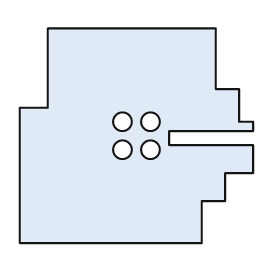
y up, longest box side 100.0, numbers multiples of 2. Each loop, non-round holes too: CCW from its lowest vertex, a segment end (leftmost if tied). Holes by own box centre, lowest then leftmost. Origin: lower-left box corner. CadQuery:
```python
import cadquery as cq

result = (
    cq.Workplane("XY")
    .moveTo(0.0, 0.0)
    .lineTo(78.0, 0.0)
    .lineTo(78.0, 18.0)
    .lineTo(88.0, 18.0)
    .lineTo(88.0, 30.0)
    .lineTo(100.0, 30.0)
    .lineTo(100.0, 42.0)
    .lineTo(64.0, 42.0)
    .lineTo(64.0, 48.0)
    .lineTo(100.0, 48.0)
    .lineTo(100.0, 52.0)
    .lineTo(94.0, 52.0)
    .lineTo(94.0, 66.0)
    .lineTo(84.0, 66.0)
    .lineTo(84.0, 92.0)
    .lineTo(12.0, 92.0)
    .lineTo(12.0, 58.0)
    .lineTo(0.0, 58.0)
    .close()
    .moveTo(44.0, 40.0)
    .circle(4.0)
    .moveTo(56.0, 40.0)
    .circle(4.0)
    .moveTo(44.0, 52.0)
    .circle(4.0)
    .moveTo(56.0, 52.0)
    .circle(4.0)
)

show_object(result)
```